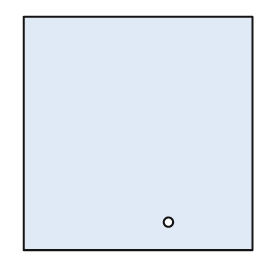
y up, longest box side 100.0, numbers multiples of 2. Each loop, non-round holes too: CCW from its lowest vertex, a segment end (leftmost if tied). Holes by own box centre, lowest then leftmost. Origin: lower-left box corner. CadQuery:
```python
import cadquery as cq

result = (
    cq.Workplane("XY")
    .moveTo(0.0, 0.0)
    .lineTo(98.0, 0.0)
    .lineTo(98.0, 100.0)
    .lineTo(0.0, 100.0)
    .close()
    .moveTo(62.0, 12.0)
    .circle(2.0)
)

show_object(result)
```